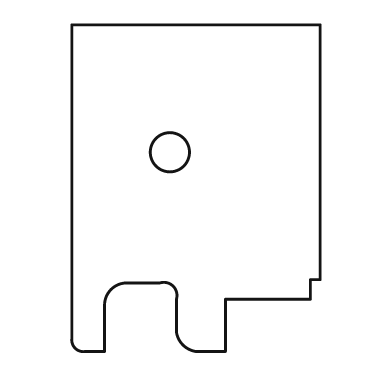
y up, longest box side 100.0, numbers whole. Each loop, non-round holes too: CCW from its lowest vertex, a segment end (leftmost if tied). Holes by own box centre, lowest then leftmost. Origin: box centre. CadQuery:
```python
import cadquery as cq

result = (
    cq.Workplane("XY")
    .moveTo(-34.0, -50.0)
    .lineTo(-28.0, -50.0)
    .lineTo(-28.0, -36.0)
    .threePointArc((-26.0, -31.0), (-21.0, -29.0))
    .lineTo(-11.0, -29.0)
    .threePointArc((-7.0, -30.0), (-6.0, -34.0))
    .lineTo(-6.0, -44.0)
    .threePointArc((-4.0, -48.0), (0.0, -50.0))
    .lineTo(9.0, -50.0)
    .lineTo(9.0, -34.0)
    .lineTo(35.0, -34.0)
    .lineTo(35.0, -28.0)
    .lineTo(38.0, -28.0)
    .lineTo(38.0, 50.0)
    .lineTo(-38.0, 50.0)
    .lineTo(-38.0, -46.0)
    .threePointArc((-37.0, -49.0), (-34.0, -50.0))
    .close()
    .moveTo(-8.0, 11.0)
    .circle(6.0)
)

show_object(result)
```